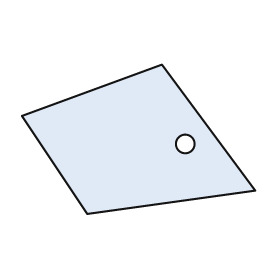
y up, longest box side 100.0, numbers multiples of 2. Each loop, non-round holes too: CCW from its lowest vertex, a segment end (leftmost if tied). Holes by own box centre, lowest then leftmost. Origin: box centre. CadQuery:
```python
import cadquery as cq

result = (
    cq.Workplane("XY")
    .moveTo(-22.0, -32.0)
    .lineTo(50.0, -22.0)
    .lineTo(10.0, 32.0)
    .lineTo(-50.0, 10.0)
    .close()
    .moveTo(20.0, -2.0)
    .circle(4.0)
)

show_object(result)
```